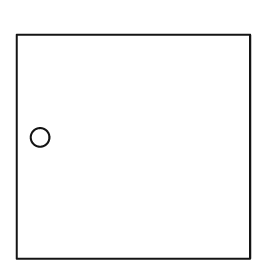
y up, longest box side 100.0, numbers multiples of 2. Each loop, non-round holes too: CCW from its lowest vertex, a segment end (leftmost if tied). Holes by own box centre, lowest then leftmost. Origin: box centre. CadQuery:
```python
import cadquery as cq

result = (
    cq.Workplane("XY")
    .moveTo(-50.0, -48.0)
    .lineTo(50.0, -48.0)
    .lineTo(50.0, 48.0)
    .lineTo(-50.0, 48.0)
    .close()
    .moveTo(-40.0, 4.0)
    .circle(4.0)
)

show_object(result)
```